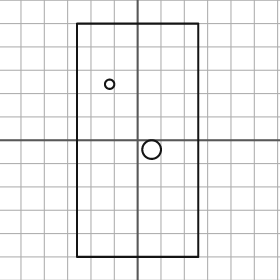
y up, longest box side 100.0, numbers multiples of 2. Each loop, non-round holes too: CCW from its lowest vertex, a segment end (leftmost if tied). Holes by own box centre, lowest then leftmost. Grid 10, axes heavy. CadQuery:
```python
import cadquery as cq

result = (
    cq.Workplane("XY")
    .moveTo(-26.0, -50.0)
    .lineTo(26.0, -50.0)
    .lineTo(26.0, 50.0)
    .lineTo(-26.0, 50.0)
    .close()
    .moveTo(6.0, -4.0)
    .circle(4.0)
    .moveTo(-12.0, 24.0)
    .circle(2.0)
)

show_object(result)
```